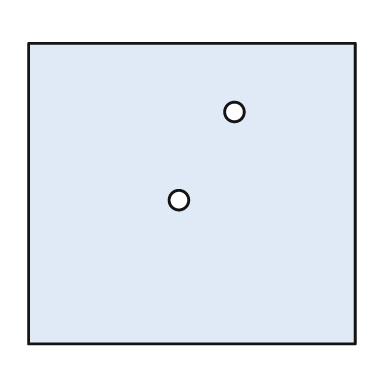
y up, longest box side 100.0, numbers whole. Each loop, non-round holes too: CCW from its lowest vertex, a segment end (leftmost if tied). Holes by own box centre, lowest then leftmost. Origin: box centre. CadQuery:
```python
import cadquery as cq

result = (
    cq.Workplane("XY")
    .moveTo(-50.0, -46.0)
    .lineTo(50.0, -46.0)
    .lineTo(50.0, 46.0)
    .lineTo(-50.0, 46.0)
    .close()
    .moveTo(-4.0, -2.0)
    .circle(3.0)
    .moveTo(13.0, 25.0)
    .circle(3.0)
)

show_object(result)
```